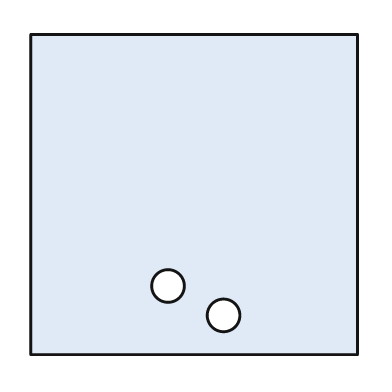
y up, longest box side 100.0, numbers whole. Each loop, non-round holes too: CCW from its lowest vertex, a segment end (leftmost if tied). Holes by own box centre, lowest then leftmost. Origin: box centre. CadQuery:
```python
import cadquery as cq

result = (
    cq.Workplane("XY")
    .moveTo(-50.0, -49.0)
    .lineTo(50.0, -49.0)
    .lineTo(50.0, 49.0)
    .lineTo(-50.0, 49.0)
    .close()
    .moveTo(9.0, -37.0)
    .circle(5.0)
    .moveTo(-8.0, -28.0)
    .circle(5.0)
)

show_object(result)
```